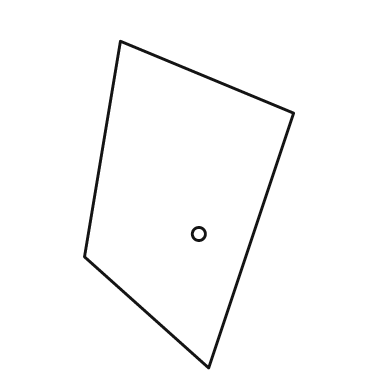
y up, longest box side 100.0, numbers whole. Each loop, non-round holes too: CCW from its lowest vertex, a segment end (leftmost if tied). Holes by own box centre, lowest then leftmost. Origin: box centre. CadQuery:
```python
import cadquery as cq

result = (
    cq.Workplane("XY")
    .moveTo(6.0, -50.0)
    .lineTo(32.0, 28.0)
    .lineTo(-21.0, 50.0)
    .lineTo(-32.0, -16.0)
    .close()
    .moveTo(3.0, -9.0)
    .circle(2.0)
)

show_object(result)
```